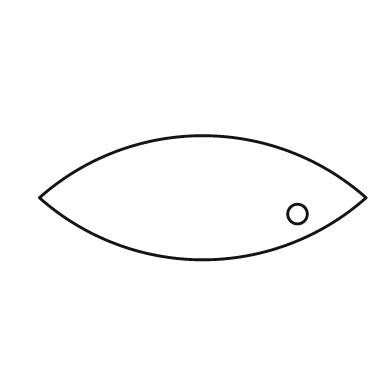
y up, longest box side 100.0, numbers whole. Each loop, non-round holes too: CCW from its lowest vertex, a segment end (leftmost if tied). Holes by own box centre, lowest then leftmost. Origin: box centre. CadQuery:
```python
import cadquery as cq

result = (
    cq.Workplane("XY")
    .moveTo(-50.0, 0.0)
    .threePointArc((0.0, -19.0), (50.0, 0.0))
    .threePointArc((0.0, 19.0), (-50.0, 0.0))
    .close()
    .moveTo(29.0, -5.0)
    .circle(3.0)
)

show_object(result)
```